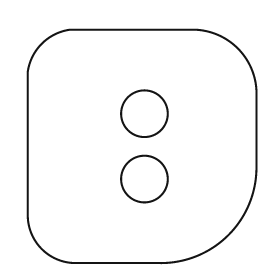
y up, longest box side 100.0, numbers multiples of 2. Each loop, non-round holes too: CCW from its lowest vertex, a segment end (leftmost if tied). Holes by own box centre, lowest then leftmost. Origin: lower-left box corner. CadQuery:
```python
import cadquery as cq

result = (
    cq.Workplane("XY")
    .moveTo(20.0, 0.0)
    .lineTo(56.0, 0.0)
    .threePointArc((86.0, 12.0), (98.0, 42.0))
    .lineTo(98.0, 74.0)
    .threePointArc((90.0, 92.0), (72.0, 100.0))
    .lineTo(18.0, 100.0)
    .threePointArc((6.0, 94.0), (0.0, 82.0))
    .lineTo(0.0, 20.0)
    .threePointArc((6.0, 6.0), (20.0, 0.0))
    .close()
    .moveTo(50.0, 36.0)
    .circle(10.0)
    .moveTo(50.0, 64.0)
    .circle(10.0)
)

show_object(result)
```